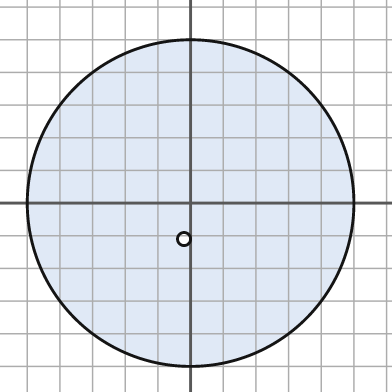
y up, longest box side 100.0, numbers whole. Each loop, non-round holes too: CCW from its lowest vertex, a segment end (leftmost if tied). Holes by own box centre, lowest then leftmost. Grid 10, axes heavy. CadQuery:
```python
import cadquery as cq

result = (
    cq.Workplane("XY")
    .moveTo(0.0, 0.0)
    .circle(50.0)
    .moveTo(-2.0, -11.0)
    .circle(2.0)
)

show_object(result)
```